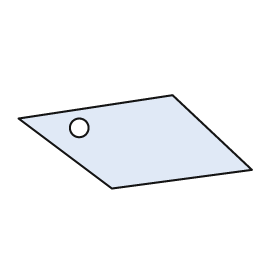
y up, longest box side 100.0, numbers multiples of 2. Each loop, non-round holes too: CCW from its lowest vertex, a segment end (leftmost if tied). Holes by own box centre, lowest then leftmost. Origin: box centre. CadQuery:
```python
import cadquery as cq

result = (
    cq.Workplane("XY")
    .moveTo(-10.0, -20.0)
    .lineTo(50.0, -12.0)
    .lineTo(16.0, 20.0)
    .lineTo(-50.0, 10.0)
    .close()
    .moveTo(-24.0, 6.0)
    .circle(4.0)
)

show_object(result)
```